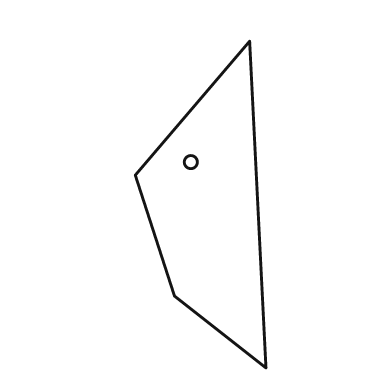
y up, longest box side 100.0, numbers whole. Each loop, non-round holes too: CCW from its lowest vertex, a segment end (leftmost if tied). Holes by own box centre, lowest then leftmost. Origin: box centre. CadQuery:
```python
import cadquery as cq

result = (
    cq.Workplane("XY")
    .moveTo(20.0, -50.0)
    .lineTo(15.0, 50.0)
    .lineTo(-20.0, 9.0)
    .lineTo(-8.0, -28.0)
    .close()
    .moveTo(-3.0, 13.0)
    .circle(2.0)
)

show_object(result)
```